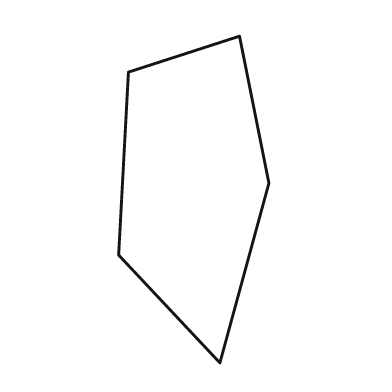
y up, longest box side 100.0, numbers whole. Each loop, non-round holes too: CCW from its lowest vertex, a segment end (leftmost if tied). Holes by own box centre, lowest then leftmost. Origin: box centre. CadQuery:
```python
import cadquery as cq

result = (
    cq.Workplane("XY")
    .moveTo(8.0, -50.0)
    .lineTo(23.0, 5.0)
    .lineTo(14.0, 50.0)
    .lineTo(-20.0, 39.0)
    .lineTo(-23.0, -17.0)
    .close()
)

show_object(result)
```